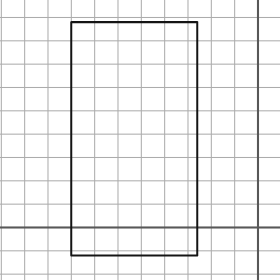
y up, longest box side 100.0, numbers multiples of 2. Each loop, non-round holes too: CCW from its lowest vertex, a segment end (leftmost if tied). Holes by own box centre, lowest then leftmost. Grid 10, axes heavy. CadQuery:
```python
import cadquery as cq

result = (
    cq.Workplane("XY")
    .moveTo(-80.0, -12.0)
    .lineTo(-26.0, -12.0)
    .lineTo(-26.0, 88.0)
    .lineTo(-80.0, 88.0)
    .close()
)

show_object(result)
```